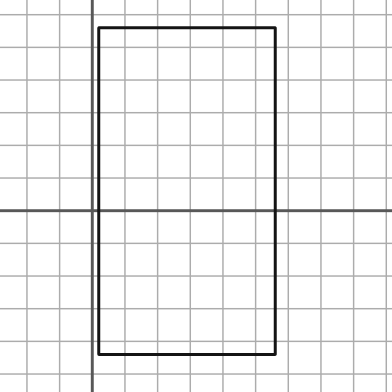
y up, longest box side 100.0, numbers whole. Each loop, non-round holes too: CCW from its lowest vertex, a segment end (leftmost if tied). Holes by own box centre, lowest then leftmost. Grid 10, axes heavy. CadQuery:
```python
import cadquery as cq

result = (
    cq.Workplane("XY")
    .moveTo(2.0, -44.0)
    .lineTo(56.0, -44.0)
    .lineTo(56.0, 56.0)
    .lineTo(2.0, 56.0)
    .close()
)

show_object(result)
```